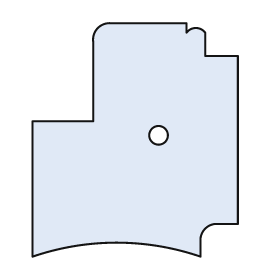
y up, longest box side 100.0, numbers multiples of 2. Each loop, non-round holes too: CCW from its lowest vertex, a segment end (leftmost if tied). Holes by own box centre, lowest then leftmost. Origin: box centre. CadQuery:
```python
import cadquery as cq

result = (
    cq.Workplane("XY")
    .moveTo(-44.0, -50.0)
    .threePointArc((-8.0, -44.0), (28.0, -50.0))
    .lineTo(28.0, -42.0)
    .threePointArc((30.0, -38.0), (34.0, -36.0))
    .lineTo(44.0, -36.0)
    .lineTo(44.0, 36.0)
    .lineTo(30.0, 36.0)
    .lineTo(30.0, 46.0)
    .threePointArc((26.0, 48.0), (22.0, 46.0))
    .lineTo(22.0, 50.0)
    .lineTo(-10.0, 50.0)
    .threePointArc((-16.0, 48.0), (-18.0, 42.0))
    .lineTo(-18.0, 8.0)
    .lineTo(-44.0, 8.0)
    .close()
    .moveTo(10.0, 2.0)
    .circle(4.0)
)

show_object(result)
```